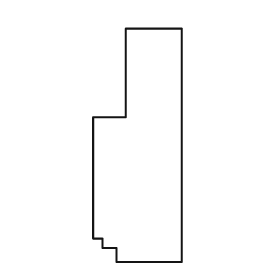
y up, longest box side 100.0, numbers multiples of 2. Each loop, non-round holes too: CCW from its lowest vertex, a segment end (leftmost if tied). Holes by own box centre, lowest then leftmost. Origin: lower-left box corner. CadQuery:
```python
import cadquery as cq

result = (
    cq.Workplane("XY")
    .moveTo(10.0, 0.0)
    .lineTo(38.0, 0.0)
    .lineTo(38.0, 100.0)
    .lineTo(14.0, 100.0)
    .lineTo(14.0, 62.0)
    .lineTo(0.0, 62.0)
    .lineTo(0.0, 10.0)
    .lineTo(4.0, 10.0)
    .lineTo(4.0, 6.0)
    .lineTo(10.0, 6.0)
    .close()
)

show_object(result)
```